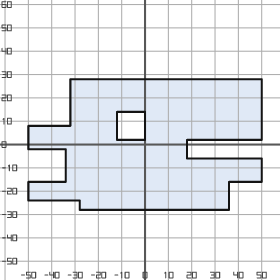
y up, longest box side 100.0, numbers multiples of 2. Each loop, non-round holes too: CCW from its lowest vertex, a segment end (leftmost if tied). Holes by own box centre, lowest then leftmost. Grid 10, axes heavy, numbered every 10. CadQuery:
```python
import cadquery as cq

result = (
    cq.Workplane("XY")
    .moveTo(-28.0, -28.0)
    .lineTo(36.0, -28.0)
    .lineTo(36.0, -16.0)
    .lineTo(50.0, -16.0)
    .lineTo(50.0, -6.0)
    .lineTo(18.0, -6.0)
    .lineTo(18.0, 2.0)
    .lineTo(50.0, 2.0)
    .lineTo(50.0, 28.0)
    .lineTo(-32.0, 28.0)
    .lineTo(-32.0, 8.0)
    .lineTo(-50.0, 8.0)
    .lineTo(-50.0, -2.0)
    .lineTo(-34.0, -2.0)
    .lineTo(-34.0, -16.0)
    .lineTo(-50.0, -16.0)
    .lineTo(-50.0, -24.0)
    .lineTo(-28.0, -24.0)
    .close()
    .moveTo(-12.0, 2.0)
    .lineTo(0.0, 2.0)
    .lineTo(0.0, 14.0)
    .lineTo(-12.0, 14.0)
    .close()
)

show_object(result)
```